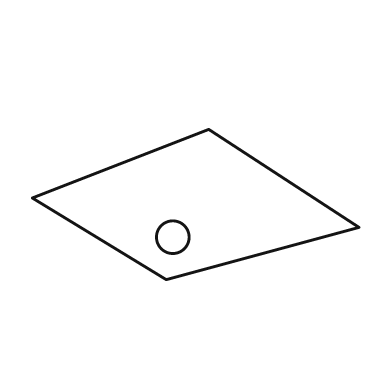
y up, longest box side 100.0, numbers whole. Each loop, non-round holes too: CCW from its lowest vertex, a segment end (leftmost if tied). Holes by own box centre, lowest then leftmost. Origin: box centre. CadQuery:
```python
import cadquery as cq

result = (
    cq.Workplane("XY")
    .moveTo(-9.0, -23.0)
    .lineTo(50.0, -7.0)
    .lineTo(4.0, 23.0)
    .lineTo(-50.0, 2.0)
    .close()
    .moveTo(-7.0, -10.0)
    .circle(5.0)
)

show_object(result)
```